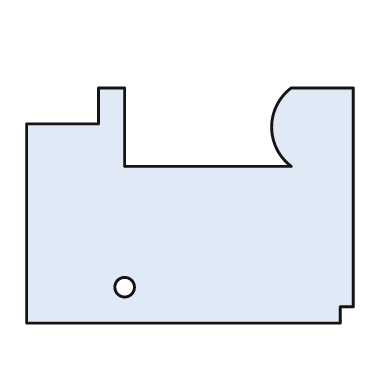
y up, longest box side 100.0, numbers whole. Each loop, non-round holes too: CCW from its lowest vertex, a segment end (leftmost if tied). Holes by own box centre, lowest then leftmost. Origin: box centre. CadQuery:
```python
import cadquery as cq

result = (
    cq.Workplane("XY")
    .moveTo(-50.0, -36.0)
    .lineTo(46.0, -36.0)
    .lineTo(46.0, -31.0)
    .lineTo(50.0, -31.0)
    .lineTo(50.0, 36.0)
    .lineTo(31.0, 36.0)
    .threePointArc((25.0, 24.0), (31.0, 12.0))
    .lineTo(-20.0, 12.0)
    .lineTo(-20.0, 36.0)
    .lineTo(-28.0, 36.0)
    .lineTo(-28.0, 25.0)
    .lineTo(-50.0, 25.0)
    .close()
    .moveTo(-20.0, -25.0)
    .circle(3.0)
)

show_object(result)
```